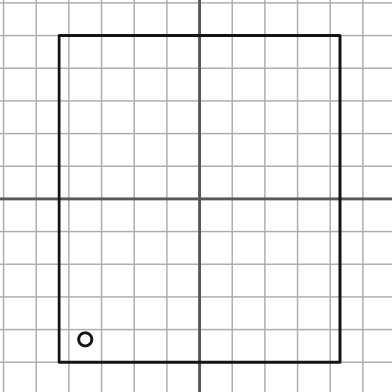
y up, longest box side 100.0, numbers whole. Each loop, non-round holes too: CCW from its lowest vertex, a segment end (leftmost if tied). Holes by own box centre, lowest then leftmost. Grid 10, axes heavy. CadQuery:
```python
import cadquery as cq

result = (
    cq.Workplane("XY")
    .moveTo(-43.0, -50.0)
    .lineTo(43.0, -50.0)
    .lineTo(43.0, 50.0)
    .lineTo(-43.0, 50.0)
    .close()
    .moveTo(-35.0, -43.0)
    .circle(2.0)
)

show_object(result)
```